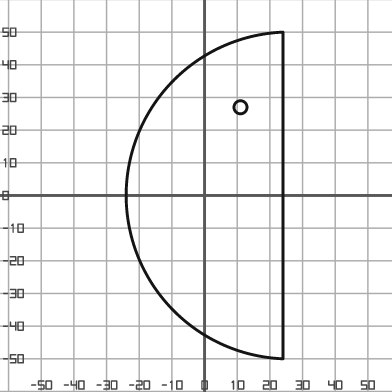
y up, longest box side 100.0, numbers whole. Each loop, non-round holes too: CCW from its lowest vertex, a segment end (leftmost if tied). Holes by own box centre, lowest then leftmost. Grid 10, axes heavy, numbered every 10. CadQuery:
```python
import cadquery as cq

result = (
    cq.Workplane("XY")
    .moveTo(24.0, -50.0)
    .lineTo(24.0, 50.0)
    .threePointArc((-24.0, 0.0), (24.0, -50.0))
    .close()
    .moveTo(11.0, 27.0)
    .circle(2.0)
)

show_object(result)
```